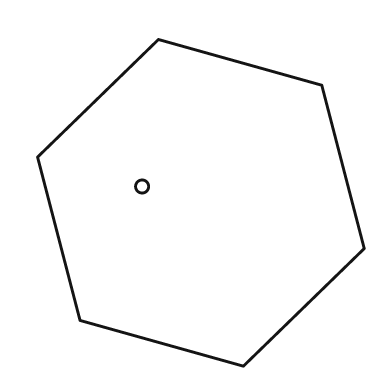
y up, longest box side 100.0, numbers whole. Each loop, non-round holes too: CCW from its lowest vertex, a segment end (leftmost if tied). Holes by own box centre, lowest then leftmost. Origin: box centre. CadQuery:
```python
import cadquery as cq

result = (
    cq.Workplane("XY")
    .moveTo(13.0, -50.0)
    .lineTo(50.0, -14.0)
    .lineTo(37.0, 36.0)
    .lineTo(-13.0, 50.0)
    .lineTo(-50.0, 14.0)
    .lineTo(-37.0, -36.0)
    .close()
    .moveTo(-18.0, 5.0)
    .circle(2.0)
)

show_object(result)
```